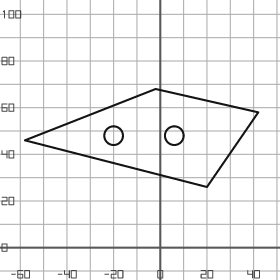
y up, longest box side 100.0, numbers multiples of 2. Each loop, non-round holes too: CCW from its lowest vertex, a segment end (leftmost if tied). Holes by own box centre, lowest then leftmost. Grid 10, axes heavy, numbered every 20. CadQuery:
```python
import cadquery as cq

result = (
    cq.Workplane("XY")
    .moveTo(20.0, 26.0)
    .lineTo(42.0, 58.0)
    .lineTo(-2.0, 68.0)
    .lineTo(-58.0, 46.0)
    .close()
    .moveTo(-20.0, 48.0)
    .circle(4.0)
    .moveTo(6.0, 48.0)
    .circle(4.0)
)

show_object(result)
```